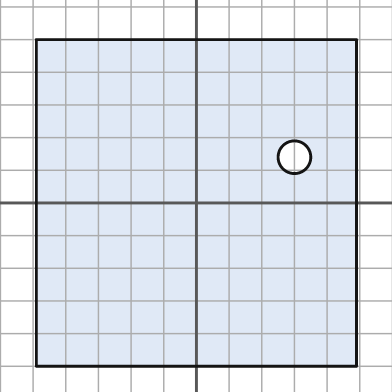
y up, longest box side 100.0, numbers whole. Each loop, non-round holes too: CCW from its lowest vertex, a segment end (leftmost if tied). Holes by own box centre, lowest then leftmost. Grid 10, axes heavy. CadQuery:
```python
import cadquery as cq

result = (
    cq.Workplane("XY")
    .moveTo(-49.0, -50.0)
    .lineTo(49.0, -50.0)
    .lineTo(49.0, 50.0)
    .lineTo(-49.0, 50.0)
    .close()
    .moveTo(30.0, 14.0)
    .circle(5.0)
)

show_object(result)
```